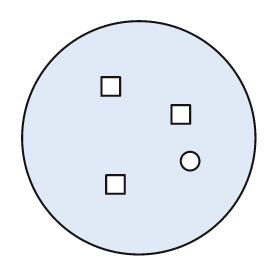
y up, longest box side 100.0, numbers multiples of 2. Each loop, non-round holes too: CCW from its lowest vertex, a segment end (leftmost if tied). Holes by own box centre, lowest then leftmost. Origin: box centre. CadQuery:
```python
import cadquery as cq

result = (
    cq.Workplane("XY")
    .moveTo(0.0, 0.0)
    .circle(50.0)
    .moveTo(-14.0, -24.0)
    .lineTo(-6.0, -24.0)
    .lineTo(-6.0, -16.0)
    .lineTo(-14.0, -16.0)
    .close()
    .moveTo(22.0, -10.0)
    .circle(4.0)
    .moveTo(14.0, 6.0)
    .lineTo(22.0, 6.0)
    .lineTo(22.0, 14.0)
    .lineTo(14.0, 14.0)
    .close()
    .moveTo(-16.0, 18.0)
    .lineTo(-8.0, 18.0)
    .lineTo(-8.0, 26.0)
    .lineTo(-16.0, 26.0)
    .close()
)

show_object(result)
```